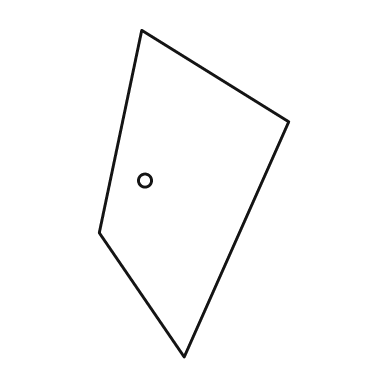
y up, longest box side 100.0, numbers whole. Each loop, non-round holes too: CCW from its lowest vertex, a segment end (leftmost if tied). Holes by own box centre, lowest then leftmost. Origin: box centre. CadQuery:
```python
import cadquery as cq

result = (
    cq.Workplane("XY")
    .moveTo(-3.0, -50.0)
    .lineTo(29.0, 22.0)
    .lineTo(-16.0, 50.0)
    .lineTo(-29.0, -12.0)
    .close()
    .moveTo(-15.0, 4.0)
    .circle(2.0)
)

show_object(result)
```